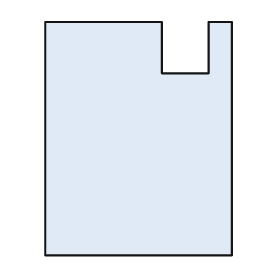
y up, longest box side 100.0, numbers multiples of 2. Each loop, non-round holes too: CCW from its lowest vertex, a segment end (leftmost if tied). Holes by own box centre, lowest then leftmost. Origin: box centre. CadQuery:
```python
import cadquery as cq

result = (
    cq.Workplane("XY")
    .moveTo(-40.0, -50.0)
    .lineTo(40.0, -50.0)
    .lineTo(40.0, 50.0)
    .lineTo(30.0, 50.0)
    .lineTo(30.0, 28.0)
    .lineTo(10.0, 28.0)
    .lineTo(10.0, 50.0)
    .lineTo(-40.0, 50.0)
    .close()
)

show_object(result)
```